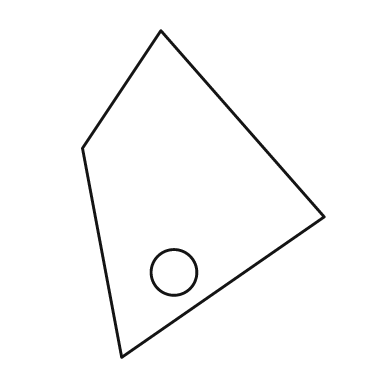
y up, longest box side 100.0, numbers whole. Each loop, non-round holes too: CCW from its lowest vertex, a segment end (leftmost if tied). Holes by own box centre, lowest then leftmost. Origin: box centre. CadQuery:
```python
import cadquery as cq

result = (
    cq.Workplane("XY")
    .moveTo(-25.0, -50.0)
    .lineTo(37.0, -7.0)
    .lineTo(-13.0, 50.0)
    .lineTo(-37.0, 14.0)
    .close()
    .moveTo(-9.0, -24.0)
    .circle(7.0)
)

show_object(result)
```